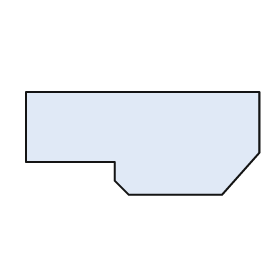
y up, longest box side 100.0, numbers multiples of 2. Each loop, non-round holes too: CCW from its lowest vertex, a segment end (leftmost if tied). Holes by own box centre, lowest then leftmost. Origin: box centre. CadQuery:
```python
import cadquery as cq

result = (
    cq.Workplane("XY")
    .moveTo(-6.0, -22.0)
    .lineTo(34.0, -22.0)
    .lineTo(50.0, -4.0)
    .lineTo(50.0, 22.0)
    .lineTo(-50.0, 22.0)
    .lineTo(-50.0, -8.0)
    .lineTo(-12.0, -8.0)
    .lineTo(-12.0, -16.0)
    .close()
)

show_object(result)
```